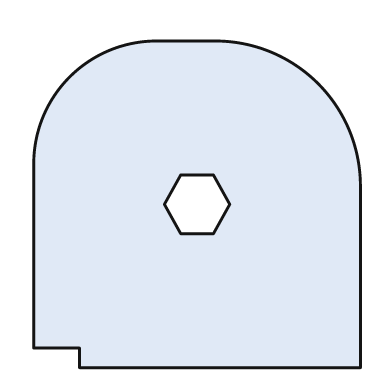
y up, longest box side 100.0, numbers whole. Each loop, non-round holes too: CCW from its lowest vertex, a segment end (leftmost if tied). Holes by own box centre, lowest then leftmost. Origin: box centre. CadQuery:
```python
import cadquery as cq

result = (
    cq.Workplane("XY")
    .moveTo(-36.0, -50.0)
    .lineTo(50.0, -50.0)
    .lineTo(50.0, 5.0)
    .threePointArc((37.0, 37.0), (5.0, 50.0))
    .lineTo(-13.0, 50.0)
    .threePointArc((-39.0, 39.0), (-50.0, 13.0))
    .lineTo(-50.0, -44.0)
    .lineTo(-36.0, -44.0)
    .close()
    .moveTo(-5.0, -9.0)
    .lineTo(5.0, -9.0)
    .lineTo(10.0, 0.0)
    .lineTo(5.0, 9.0)
    .lineTo(-5.0, 9.0)
    .lineTo(-10.0, 0.0)
    .close()
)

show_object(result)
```